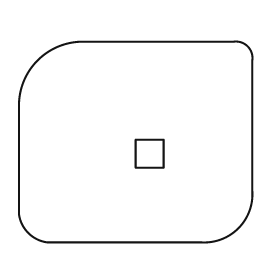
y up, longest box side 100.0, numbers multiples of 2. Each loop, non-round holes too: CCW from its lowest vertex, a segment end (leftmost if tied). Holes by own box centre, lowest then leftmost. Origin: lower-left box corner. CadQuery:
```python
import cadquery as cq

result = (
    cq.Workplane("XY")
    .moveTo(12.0, 0.0)
    .lineTo(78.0, 0.0)
    .threePointArc((94.0, 6.0), (100.0, 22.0))
    .lineTo(100.0, 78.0)
    .threePointArc((98.0, 84.0), (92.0, 86.0))
    .lineTo(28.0, 86.0)
    .threePointArc((8.0, 78.0), (0.0, 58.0))
    .lineTo(0.0, 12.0)
    .threePointArc((4.0, 4.0), (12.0, 0.0))
    .close()
    .moveTo(50.0, 32.0)
    .lineTo(62.0, 32.0)
    .lineTo(62.0, 44.0)
    .lineTo(50.0, 44.0)
    .close()
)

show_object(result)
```